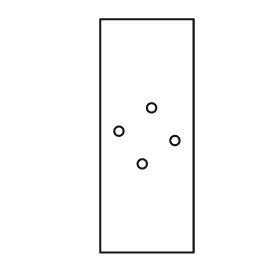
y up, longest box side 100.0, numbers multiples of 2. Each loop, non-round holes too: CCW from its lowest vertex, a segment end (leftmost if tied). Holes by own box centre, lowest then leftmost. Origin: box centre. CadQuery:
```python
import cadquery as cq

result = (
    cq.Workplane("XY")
    .moveTo(-20.0, -50.0)
    .lineTo(20.0, -50.0)
    .lineTo(20.0, 50.0)
    .lineTo(-20.0, 50.0)
    .close()
    .moveTo(-2.0, -12.0)
    .circle(2.0)
    .moveTo(12.0, -2.0)
    .circle(2.0)
    .moveTo(-12.0, 2.0)
    .circle(2.0)
    .moveTo(2.0, 12.0)
    .circle(2.0)
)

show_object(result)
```